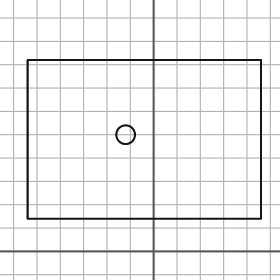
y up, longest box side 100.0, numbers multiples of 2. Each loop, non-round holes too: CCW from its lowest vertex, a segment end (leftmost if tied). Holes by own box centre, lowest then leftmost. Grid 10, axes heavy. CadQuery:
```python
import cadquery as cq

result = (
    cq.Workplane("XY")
    .moveTo(-54.0, 14.0)
    .lineTo(46.0, 14.0)
    .lineTo(46.0, 82.0)
    .lineTo(-54.0, 82.0)
    .close()
    .moveTo(-12.0, 50.0)
    .circle(4.0)
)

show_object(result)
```